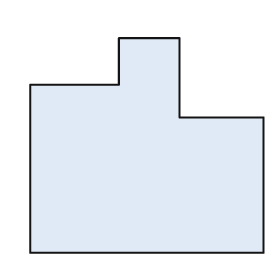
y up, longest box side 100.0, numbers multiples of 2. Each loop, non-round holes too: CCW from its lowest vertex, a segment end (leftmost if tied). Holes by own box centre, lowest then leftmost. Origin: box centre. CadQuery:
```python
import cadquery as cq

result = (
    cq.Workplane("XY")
    .moveTo(-50.0, -46.0)
    .lineTo(50.0, -46.0)
    .lineTo(50.0, 12.0)
    .lineTo(14.0, 12.0)
    .lineTo(14.0, 46.0)
    .lineTo(-12.0, 46.0)
    .lineTo(-12.0, 26.0)
    .lineTo(-50.0, 26.0)
    .close()
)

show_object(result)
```